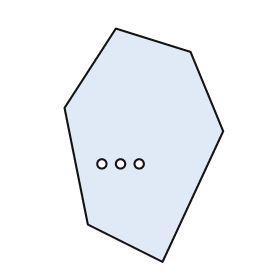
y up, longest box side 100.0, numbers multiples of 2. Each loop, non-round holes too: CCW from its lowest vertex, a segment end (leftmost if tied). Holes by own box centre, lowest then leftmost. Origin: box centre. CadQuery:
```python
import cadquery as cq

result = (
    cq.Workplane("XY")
    .moveTo(8.0, -50.0)
    .lineTo(34.0, 6.0)
    .lineTo(20.0, 40.0)
    .lineTo(-12.0, 50.0)
    .lineTo(-34.0, 16.0)
    .lineTo(-24.0, -34.0)
    .close()
    .moveTo(-18.0, -8.0)
    .circle(2.0)
    .moveTo(-10.0, -8.0)
    .circle(2.0)
    .moveTo(-2.0, -8.0)
    .circle(2.0)
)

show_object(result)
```